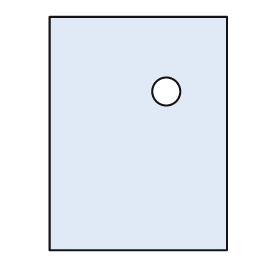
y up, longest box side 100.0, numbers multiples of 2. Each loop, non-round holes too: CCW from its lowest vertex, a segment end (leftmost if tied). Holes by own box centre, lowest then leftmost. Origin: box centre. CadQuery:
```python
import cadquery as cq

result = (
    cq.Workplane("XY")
    .moveTo(-38.0, -50.0)
    .lineTo(38.0, -50.0)
    .lineTo(38.0, 50.0)
    .lineTo(-38.0, 50.0)
    .close()
    .moveTo(12.0, 18.0)
    .circle(6.0)
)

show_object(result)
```